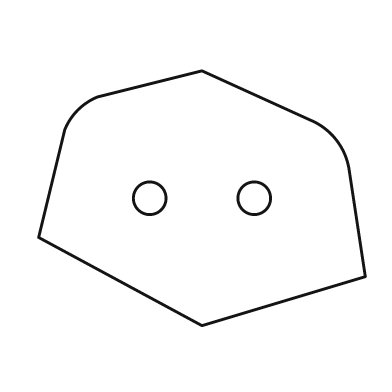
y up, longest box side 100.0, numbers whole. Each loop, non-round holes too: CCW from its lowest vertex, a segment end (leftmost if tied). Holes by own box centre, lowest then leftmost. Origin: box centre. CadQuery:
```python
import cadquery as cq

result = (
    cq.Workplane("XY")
    .moveTo(0.0, -39.0)
    .lineTo(50.0, -24.0)
    .lineTo(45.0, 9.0)
    .threePointArc((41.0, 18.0), (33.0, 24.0))
    .lineTo(0.0, 39.0)
    .lineTo(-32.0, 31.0)
    .threePointArc((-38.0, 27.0), (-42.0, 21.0))
    .lineTo(-50.0, -12.0)
    .close()
    .moveTo(-16.0, 0.0)
    .circle(5.0)
    .moveTo(16.0, 0.0)
    .circle(5.0)
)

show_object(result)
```